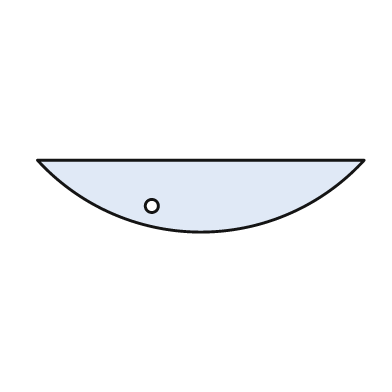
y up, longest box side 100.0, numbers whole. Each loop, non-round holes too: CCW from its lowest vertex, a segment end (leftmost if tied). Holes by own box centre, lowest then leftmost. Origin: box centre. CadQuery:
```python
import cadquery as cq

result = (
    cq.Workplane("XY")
    .moveTo(-50.0, 11.0)
    .threePointArc((0.0, -11.0), (50.0, 11.0))
    .close()
    .moveTo(-15.0, -3.0)
    .circle(2.0)
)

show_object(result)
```